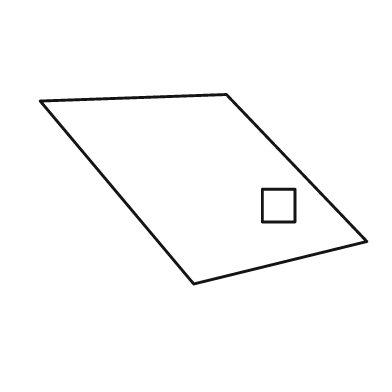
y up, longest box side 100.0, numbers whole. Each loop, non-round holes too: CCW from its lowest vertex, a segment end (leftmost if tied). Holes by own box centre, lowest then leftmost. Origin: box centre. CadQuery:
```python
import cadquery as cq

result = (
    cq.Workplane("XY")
    .moveTo(-3.0, -29.0)
    .lineTo(50.0, -16.0)
    .lineTo(7.0, 29.0)
    .lineTo(-50.0, 27.0)
    .close()
    .moveTo(18.0, -10.0)
    .lineTo(28.0, -10.0)
    .lineTo(28.0, 0.0)
    .lineTo(18.0, 0.0)
    .close()
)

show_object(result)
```